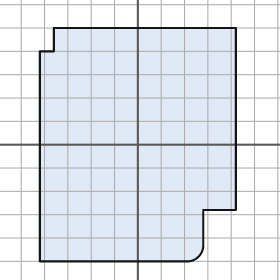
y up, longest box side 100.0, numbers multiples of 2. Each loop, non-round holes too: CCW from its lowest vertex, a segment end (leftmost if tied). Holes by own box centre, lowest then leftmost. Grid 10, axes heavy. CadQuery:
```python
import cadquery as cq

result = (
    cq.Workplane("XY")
    .moveTo(-42.0, -50.0)
    .lineTo(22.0, -50.0)
    .threePointArc((26.0, -48.0), (28.0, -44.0))
    .lineTo(28.0, -28.0)
    .lineTo(42.0, -28.0)
    .lineTo(42.0, 50.0)
    .lineTo(-36.0, 50.0)
    .lineTo(-36.0, 40.0)
    .lineTo(-42.0, 40.0)
    .close()
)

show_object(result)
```